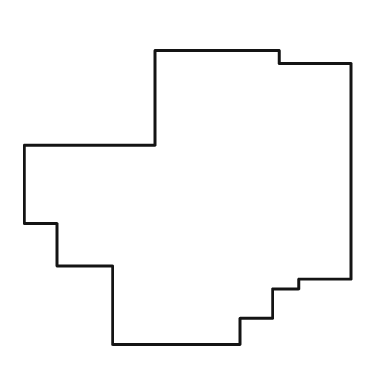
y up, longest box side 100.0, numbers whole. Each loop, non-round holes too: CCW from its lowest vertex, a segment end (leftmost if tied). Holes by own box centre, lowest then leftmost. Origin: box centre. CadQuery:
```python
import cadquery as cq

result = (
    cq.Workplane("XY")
    .moveTo(-23.0, -45.0)
    .lineTo(16.0, -45.0)
    .lineTo(16.0, -37.0)
    .lineTo(26.0, -37.0)
    .lineTo(26.0, -28.0)
    .lineTo(34.0, -28.0)
    .lineTo(34.0, -25.0)
    .lineTo(50.0, -25.0)
    .lineTo(50.0, 41.0)
    .lineTo(28.0, 41.0)
    .lineTo(28.0, 45.0)
    .lineTo(-10.0, 45.0)
    .lineTo(-10.0, 16.0)
    .lineTo(-50.0, 16.0)
    .lineTo(-50.0, -8.0)
    .lineTo(-40.0, -8.0)
    .lineTo(-40.0, -21.0)
    .lineTo(-23.0, -21.0)
    .close()
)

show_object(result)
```